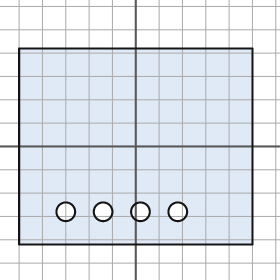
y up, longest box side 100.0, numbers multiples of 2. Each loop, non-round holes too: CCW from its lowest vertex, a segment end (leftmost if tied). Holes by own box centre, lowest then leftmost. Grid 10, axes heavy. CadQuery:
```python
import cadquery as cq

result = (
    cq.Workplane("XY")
    .moveTo(-50.0, -42.0)
    .lineTo(50.0, -42.0)
    .lineTo(50.0, 42.0)
    .lineTo(-50.0, 42.0)
    .close()
    .moveTo(-30.0, -28.0)
    .circle(4.0)
    .moveTo(-14.0, -28.0)
    .circle(4.0)
    .moveTo(2.0, -28.0)
    .circle(4.0)
    .moveTo(18.0, -28.0)
    .circle(4.0)
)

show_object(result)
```